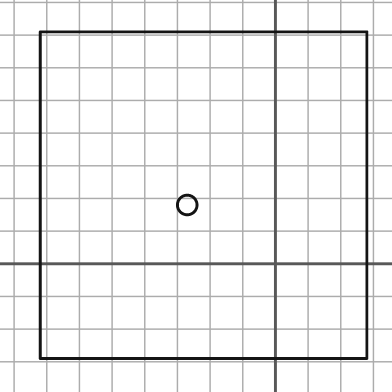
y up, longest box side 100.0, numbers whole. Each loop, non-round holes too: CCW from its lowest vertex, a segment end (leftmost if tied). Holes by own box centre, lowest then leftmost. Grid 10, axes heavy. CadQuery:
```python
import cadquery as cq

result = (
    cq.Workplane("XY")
    .moveTo(-72.0, -29.0)
    .lineTo(28.0, -29.0)
    .lineTo(28.0, 71.0)
    .lineTo(-72.0, 71.0)
    .close()
    .moveTo(-27.0, 18.0)
    .circle(3.0)
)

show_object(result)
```